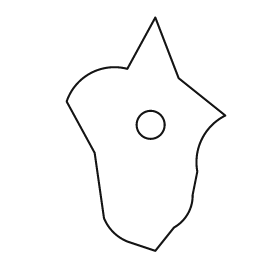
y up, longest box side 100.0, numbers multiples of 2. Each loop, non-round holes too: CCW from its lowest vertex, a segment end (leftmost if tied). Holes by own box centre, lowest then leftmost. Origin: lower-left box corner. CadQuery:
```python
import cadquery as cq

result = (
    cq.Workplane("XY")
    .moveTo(38.0, 0.0)
    .lineTo(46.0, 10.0)
    .threePointArc((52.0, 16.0), (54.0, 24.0))
    .lineTo(56.0, 34.0)
    .threePointArc((58.0, 48.0), (68.0, 58.0))
    .lineTo(48.0, 74.0)
    .lineTo(38.0, 100.0)
    .lineTo(26.0, 78.0)
    .threePointArc((10.0, 76.0), (0.0, 64.0))
    .lineTo(12.0, 42.0)
    .lineTo(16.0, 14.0)
    .threePointArc((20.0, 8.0), (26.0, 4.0))
    .close()
    .moveTo(36.0, 54.0)
    .circle(6.0)
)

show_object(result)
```